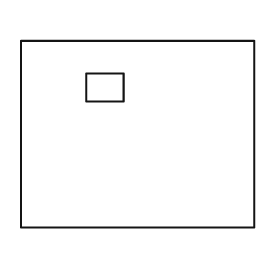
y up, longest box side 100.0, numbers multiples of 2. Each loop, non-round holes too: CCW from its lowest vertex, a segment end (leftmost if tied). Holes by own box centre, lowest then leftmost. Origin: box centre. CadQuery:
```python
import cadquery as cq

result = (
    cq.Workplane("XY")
    .moveTo(-50.0, -40.0)
    .lineTo(50.0, -40.0)
    .lineTo(50.0, 40.0)
    .lineTo(-50.0, 40.0)
    .close()
    .moveTo(-22.0, 14.0)
    .lineTo(-6.0, 14.0)
    .lineTo(-6.0, 26.0)
    .lineTo(-22.0, 26.0)
    .close()
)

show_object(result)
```